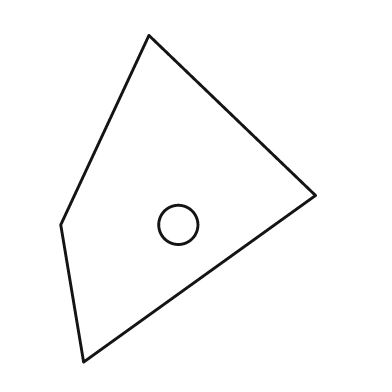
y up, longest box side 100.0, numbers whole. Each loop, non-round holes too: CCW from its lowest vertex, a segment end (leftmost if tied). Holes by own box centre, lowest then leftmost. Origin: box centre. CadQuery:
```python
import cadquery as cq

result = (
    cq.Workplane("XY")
    .moveTo(-32.0, -50.0)
    .lineTo(39.0, 1.0)
    .lineTo(-12.0, 50.0)
    .lineTo(-39.0, -8.0)
    .close()
    .moveTo(-3.0, -8.0)
    .circle(6.0)
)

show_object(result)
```